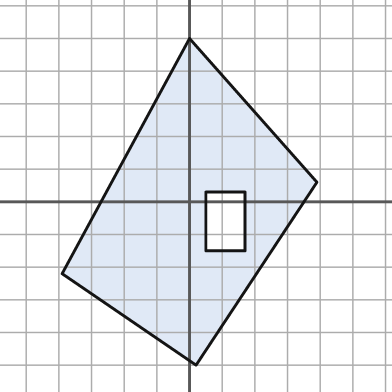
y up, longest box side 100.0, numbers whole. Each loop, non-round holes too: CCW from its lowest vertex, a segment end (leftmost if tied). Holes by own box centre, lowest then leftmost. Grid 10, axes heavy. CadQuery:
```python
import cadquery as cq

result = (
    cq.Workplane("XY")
    .moveTo(2.0, -50.0)
    .lineTo(39.0, 6.0)
    .lineTo(0.0, 50.0)
    .lineTo(-39.0, -22.0)
    .close()
    .moveTo(5.0, -15.0)
    .lineTo(17.0, -15.0)
    .lineTo(17.0, 3.0)
    .lineTo(5.0, 3.0)
    .close()
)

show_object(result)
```